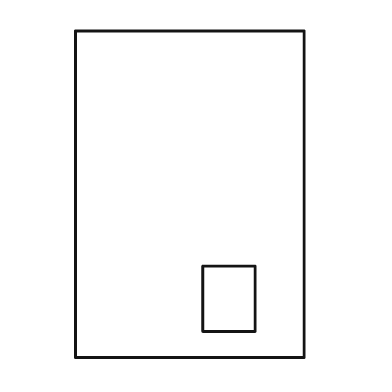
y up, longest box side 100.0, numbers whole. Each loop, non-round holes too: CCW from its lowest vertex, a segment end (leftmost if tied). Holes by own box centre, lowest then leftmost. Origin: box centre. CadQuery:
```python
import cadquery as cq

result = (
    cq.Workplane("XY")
    .moveTo(-35.0, -50.0)
    .lineTo(35.0, -50.0)
    .lineTo(35.0, 50.0)
    .lineTo(-35.0, 50.0)
    .close()
    .moveTo(4.0, -42.0)
    .lineTo(20.0, -42.0)
    .lineTo(20.0, -22.0)
    .lineTo(4.0, -22.0)
    .close()
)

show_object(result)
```